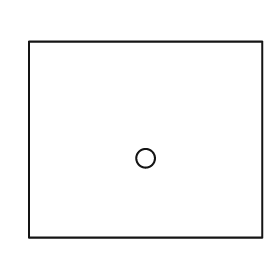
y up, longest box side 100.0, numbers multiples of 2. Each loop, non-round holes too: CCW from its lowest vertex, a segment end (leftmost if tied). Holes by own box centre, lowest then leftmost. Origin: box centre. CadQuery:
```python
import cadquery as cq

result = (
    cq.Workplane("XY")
    .moveTo(-50.0, -42.0)
    .lineTo(50.0, -42.0)
    .lineTo(50.0, 42.0)
    .lineTo(-50.0, 42.0)
    .close()
    .moveTo(0.0, -8.0)
    .circle(4.0)
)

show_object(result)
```